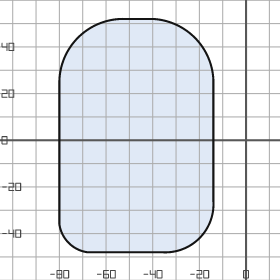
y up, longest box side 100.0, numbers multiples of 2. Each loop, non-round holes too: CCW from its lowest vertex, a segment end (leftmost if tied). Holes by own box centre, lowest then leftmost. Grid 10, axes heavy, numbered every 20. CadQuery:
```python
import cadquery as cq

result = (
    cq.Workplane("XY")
    .moveTo(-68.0, -48.0)
    .lineTo(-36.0, -48.0)
    .threePointArc((-20.0, -42.0), (-14.0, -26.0))
    .lineTo(-14.0, 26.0)
    .threePointArc((-22.0, 44.0), (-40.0, 52.0))
    .lineTo(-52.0, 52.0)
    .threePointArc((-72.0, 44.0), (-80.0, 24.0))
    .lineTo(-80.0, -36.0)
    .threePointArc((-76.0, -44.0), (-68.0, -48.0))
    .close()
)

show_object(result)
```